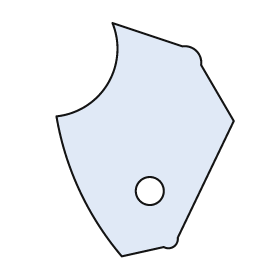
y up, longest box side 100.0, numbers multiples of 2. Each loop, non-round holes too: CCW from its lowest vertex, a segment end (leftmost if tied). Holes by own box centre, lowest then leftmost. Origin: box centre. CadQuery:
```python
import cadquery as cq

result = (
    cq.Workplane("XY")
    .moveTo(-10.0, -50.0)
    .lineTo(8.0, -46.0)
    .threePointArc((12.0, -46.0), (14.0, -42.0))
    .lineTo(38.0, 8.0)
    .lineTo(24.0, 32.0)
    .threePointArc((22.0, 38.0), (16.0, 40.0))
    .lineTo(-14.0, 50.0)
    .threePointArc((-16.0, 24.0), (-38.0, 10.0))
    .threePointArc((-28.0, -22.0), (-10.0, -50.0))
    .close()
    .moveTo(2.0, -22.0)
    .circle(6.0)
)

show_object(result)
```